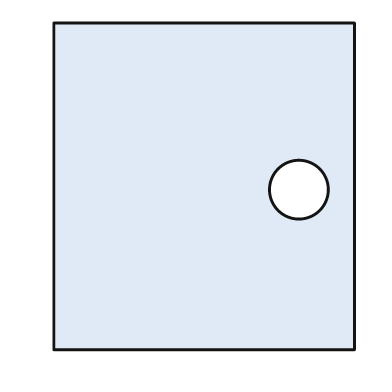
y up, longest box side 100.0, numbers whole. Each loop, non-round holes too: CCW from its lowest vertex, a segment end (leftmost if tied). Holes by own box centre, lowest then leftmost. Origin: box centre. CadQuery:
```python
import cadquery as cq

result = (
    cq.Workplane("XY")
    .moveTo(-46.0, -50.0)
    .lineTo(46.0, -50.0)
    .lineTo(46.0, 50.0)
    .lineTo(-46.0, 50.0)
    .close()
    .moveTo(29.0, -1.0)
    .circle(9.0)
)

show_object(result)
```